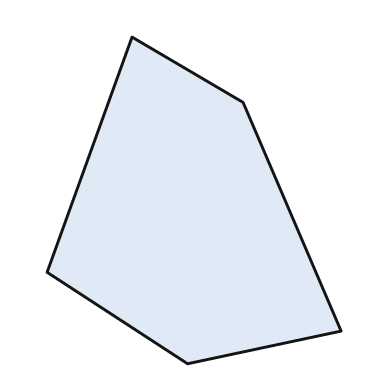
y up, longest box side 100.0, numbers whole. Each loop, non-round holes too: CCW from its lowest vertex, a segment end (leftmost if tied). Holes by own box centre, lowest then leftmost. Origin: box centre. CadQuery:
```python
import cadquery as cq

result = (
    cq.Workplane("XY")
    .moveTo(-2.0, -50.0)
    .lineTo(45.0, -40.0)
    .lineTo(15.0, 30.0)
    .lineTo(-19.0, 50.0)
    .lineTo(-45.0, -22.0)
    .close()
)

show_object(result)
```